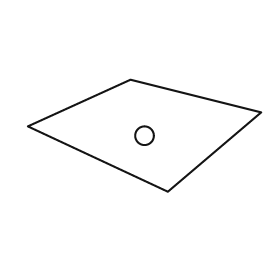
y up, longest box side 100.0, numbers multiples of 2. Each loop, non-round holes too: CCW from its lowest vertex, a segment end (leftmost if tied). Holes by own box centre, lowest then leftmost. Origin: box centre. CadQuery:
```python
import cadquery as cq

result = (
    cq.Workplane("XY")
    .moveTo(10.0, -24.0)
    .lineTo(50.0, 10.0)
    .lineTo(-6.0, 24.0)
    .lineTo(-50.0, 4.0)
    .close()
    .moveTo(0.0, 0.0)
    .circle(4.0)
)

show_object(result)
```